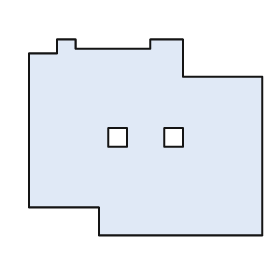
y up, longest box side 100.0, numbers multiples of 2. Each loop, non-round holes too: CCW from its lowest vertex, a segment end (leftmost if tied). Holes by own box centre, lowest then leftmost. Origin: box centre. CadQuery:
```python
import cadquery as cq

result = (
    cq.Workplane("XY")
    .moveTo(-20.0, -42.0)
    .lineTo(50.0, -42.0)
    .lineTo(50.0, 26.0)
    .lineTo(16.0, 26.0)
    .lineTo(16.0, 42.0)
    .lineTo(2.0, 42.0)
    .lineTo(2.0, 38.0)
    .lineTo(-30.0, 38.0)
    .lineTo(-30.0, 42.0)
    .lineTo(-38.0, 42.0)
    .lineTo(-38.0, 36.0)
    .lineTo(-50.0, 36.0)
    .lineTo(-50.0, -30.0)
    .lineTo(-20.0, -30.0)
    .close()
    .moveTo(-16.0, -4.0)
    .lineTo(-8.0, -4.0)
    .lineTo(-8.0, 4.0)
    .lineTo(-16.0, 4.0)
    .close()
    .moveTo(8.0, -4.0)
    .lineTo(16.0, -4.0)
    .lineTo(16.0, 4.0)
    .lineTo(8.0, 4.0)
    .close()
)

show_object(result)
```